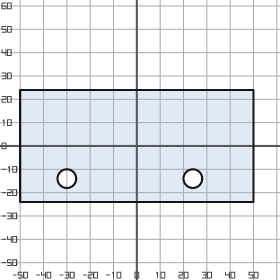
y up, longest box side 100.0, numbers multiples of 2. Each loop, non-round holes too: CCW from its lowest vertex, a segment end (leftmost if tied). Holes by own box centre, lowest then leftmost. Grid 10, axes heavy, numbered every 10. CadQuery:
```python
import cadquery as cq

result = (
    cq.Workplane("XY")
    .moveTo(-50.0, -24.0)
    .lineTo(50.0, -24.0)
    .lineTo(50.0, 24.0)
    .lineTo(-50.0, 24.0)
    .close()
    .moveTo(-30.0, -14.0)
    .circle(4.0)
    .moveTo(24.0, -14.0)
    .circle(4.0)
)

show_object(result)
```